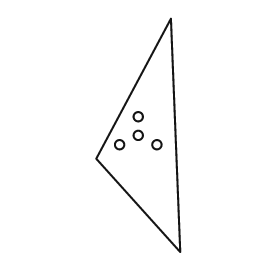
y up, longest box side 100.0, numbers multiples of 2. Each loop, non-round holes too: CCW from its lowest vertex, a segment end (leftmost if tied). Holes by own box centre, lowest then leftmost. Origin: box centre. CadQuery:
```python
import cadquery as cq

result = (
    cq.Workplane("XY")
    .moveTo(18.0, -50.0)
    .lineTo(14.0, 50.0)
    .lineTo(-18.0, -10.0)
    .close()
    .moveTo(-8.0, -4.0)
    .circle(2.0)
    .moveTo(8.0, -4.0)
    .circle(2.0)
    .moveTo(0.0, 0.0)
    .circle(2.0)
    .moveTo(0.0, 8.0)
    .circle(2.0)
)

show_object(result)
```